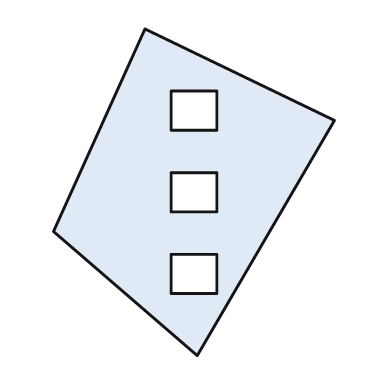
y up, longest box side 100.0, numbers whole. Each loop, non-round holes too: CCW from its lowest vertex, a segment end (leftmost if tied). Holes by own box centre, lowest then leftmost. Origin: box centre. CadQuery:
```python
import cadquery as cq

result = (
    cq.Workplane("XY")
    .moveTo(1.0, -50.0)
    .lineTo(43.0, 22.0)
    .lineTo(-15.0, 50.0)
    .lineTo(-43.0, -12.0)
    .close()
    .moveTo(-7.0, -31.0)
    .lineTo(7.0, -31.0)
    .lineTo(7.0, -19.0)
    .lineTo(-7.0, -19.0)
    .close()
    .moveTo(-7.0, -6.0)
    .lineTo(7.0, -6.0)
    .lineTo(7.0, 6.0)
    .lineTo(-7.0, 6.0)
    .close()
    .moveTo(-7.0, 19.0)
    .lineTo(7.0, 19.0)
    .lineTo(7.0, 31.0)
    .lineTo(-7.0, 31.0)
    .close()
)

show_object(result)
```